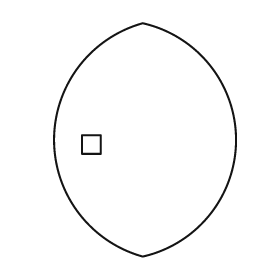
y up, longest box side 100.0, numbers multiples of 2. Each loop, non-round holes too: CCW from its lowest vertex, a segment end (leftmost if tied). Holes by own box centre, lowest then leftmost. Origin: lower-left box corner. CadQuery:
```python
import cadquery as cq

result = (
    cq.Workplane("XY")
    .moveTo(38.0, 0.0)
    .threePointArc((78.0, 50.0), (38.0, 100.0))
    .threePointArc((0.0, 50.0), (38.0, 0.0))
    .close()
    .moveTo(12.0, 44.0)
    .lineTo(20.0, 44.0)
    .lineTo(20.0, 52.0)
    .lineTo(12.0, 52.0)
    .close()
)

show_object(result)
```